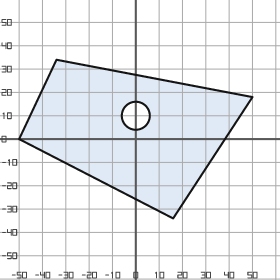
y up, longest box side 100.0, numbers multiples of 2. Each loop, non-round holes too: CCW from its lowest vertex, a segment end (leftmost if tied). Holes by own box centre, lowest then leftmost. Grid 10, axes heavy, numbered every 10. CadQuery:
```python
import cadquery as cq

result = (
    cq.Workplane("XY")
    .moveTo(16.0, -34.0)
    .lineTo(50.0, 18.0)
    .lineTo(-34.0, 34.0)
    .lineTo(-50.0, 0.0)
    .close()
    .moveTo(0.0, 10.0)
    .circle(6.0)
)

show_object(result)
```